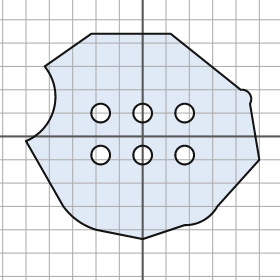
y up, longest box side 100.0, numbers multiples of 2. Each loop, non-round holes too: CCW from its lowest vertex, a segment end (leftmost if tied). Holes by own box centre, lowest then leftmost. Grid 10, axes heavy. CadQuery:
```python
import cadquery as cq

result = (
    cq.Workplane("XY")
    .moveTo(0.0, -44.0)
    .lineTo(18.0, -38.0)
    .threePointArc((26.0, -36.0), (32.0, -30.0))
    .lineTo(50.0, -10.0)
    .lineTo(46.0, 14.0)
    .threePointArc((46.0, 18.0), (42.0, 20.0))
    .lineTo(12.0, 44.0)
    .lineTo(-22.0, 44.0)
    .lineTo(-42.0, 30.0)
    .threePointArc((-38.0, 12.0), (-50.0, -2.0))
    .lineTo(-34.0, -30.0)
    .threePointArc((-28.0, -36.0), (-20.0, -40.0))
    .close()
    .moveTo(-18.0, -8.0)
    .circle(4.0)
    .moveTo(0.0, -8.0)
    .circle(4.0)
    .moveTo(18.0, -8.0)
    .circle(4.0)
    .moveTo(-18.0, 10.0)
    .circle(4.0)
    .moveTo(0.0, 10.0)
    .circle(4.0)
    .moveTo(18.0, 10.0)
    .circle(4.0)
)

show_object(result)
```